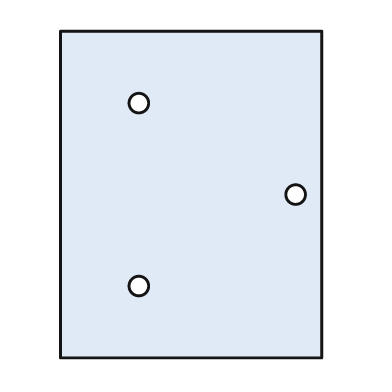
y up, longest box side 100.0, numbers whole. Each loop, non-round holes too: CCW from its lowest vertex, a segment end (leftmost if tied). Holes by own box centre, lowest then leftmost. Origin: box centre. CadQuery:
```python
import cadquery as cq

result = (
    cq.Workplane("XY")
    .moveTo(-40.0, -50.0)
    .lineTo(40.0, -50.0)
    .lineTo(40.0, 50.0)
    .lineTo(-40.0, 50.0)
    .close()
    .moveTo(-16.0, -28.0)
    .circle(3.0)
    .moveTo(32.0, 0.0)
    .circle(3.0)
    .moveTo(-16.0, 28.0)
    .circle(3.0)
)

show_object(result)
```